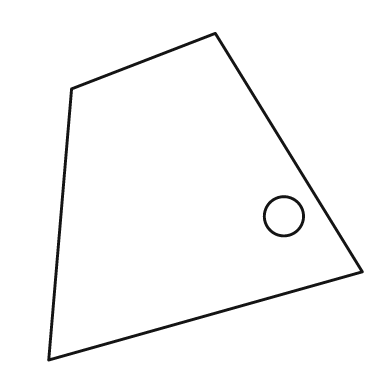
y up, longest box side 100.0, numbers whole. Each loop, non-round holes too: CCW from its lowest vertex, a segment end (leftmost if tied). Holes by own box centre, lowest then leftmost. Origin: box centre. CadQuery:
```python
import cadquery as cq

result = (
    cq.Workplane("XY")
    .moveTo(-48.0, -50.0)
    .lineTo(48.0, -23.0)
    .lineTo(3.0, 50.0)
    .lineTo(-41.0, 33.0)
    .close()
    .moveTo(24.0, -6.0)
    .circle(6.0)
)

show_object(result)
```